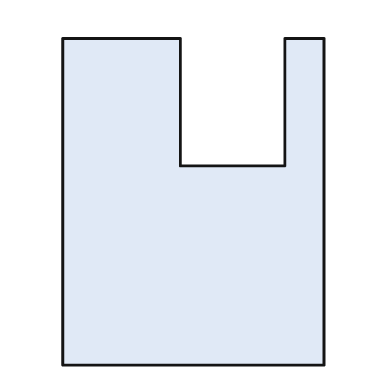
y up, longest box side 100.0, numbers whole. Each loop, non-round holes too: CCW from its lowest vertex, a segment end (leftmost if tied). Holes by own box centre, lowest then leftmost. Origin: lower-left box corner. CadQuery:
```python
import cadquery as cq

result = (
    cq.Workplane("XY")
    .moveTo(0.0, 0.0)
    .lineTo(80.0, 0.0)
    .lineTo(80.0, 100.0)
    .lineTo(68.0, 100.0)
    .lineTo(68.0, 61.0)
    .lineTo(36.0, 61.0)
    .lineTo(36.0, 100.0)
    .lineTo(0.0, 100.0)
    .close()
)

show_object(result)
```